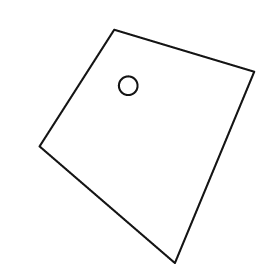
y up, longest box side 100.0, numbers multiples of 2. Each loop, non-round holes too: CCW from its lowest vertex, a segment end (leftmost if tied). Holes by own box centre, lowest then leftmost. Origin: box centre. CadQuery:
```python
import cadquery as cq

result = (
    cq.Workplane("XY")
    .moveTo(12.0, -50.0)
    .lineTo(46.0, 32.0)
    .lineTo(-14.0, 50.0)
    .lineTo(-46.0, 0.0)
    .close()
    .moveTo(-8.0, 26.0)
    .circle(4.0)
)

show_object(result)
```